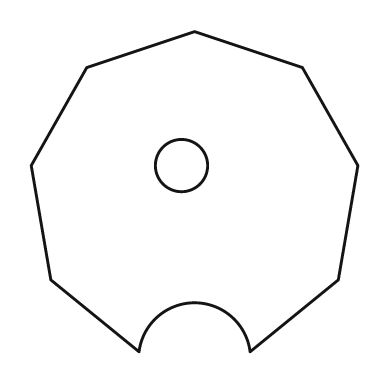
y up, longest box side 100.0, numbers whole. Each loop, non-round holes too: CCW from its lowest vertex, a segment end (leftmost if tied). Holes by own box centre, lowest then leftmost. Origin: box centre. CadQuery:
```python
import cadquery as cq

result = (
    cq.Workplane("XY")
    .moveTo(-17.0, -49.0)
    .threePointArc((0.0, -34.0), (17.0, -49.0))
    .lineTo(44.0, -27.0)
    .lineTo(50.0, 8.0)
    .lineTo(33.0, 38.0)
    .lineTo(0.0, 49.0)
    .lineTo(-33.0, 38.0)
    .lineTo(-50.0, 8.0)
    .lineTo(-44.0, -27.0)
    .close()
    .moveTo(-4.0, 8.0)
    .circle(8.0)
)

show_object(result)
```